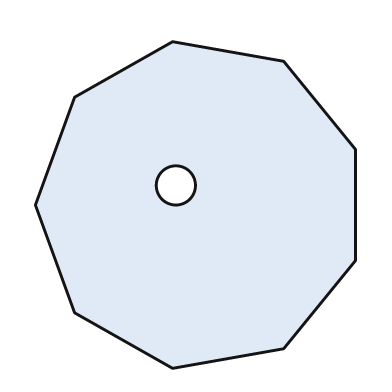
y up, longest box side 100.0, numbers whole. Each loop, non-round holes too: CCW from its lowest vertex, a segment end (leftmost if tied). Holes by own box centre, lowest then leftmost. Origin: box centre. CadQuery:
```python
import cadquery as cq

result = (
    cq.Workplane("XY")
    .moveTo(-7.0, -50.0)
    .lineTo(27.0, -44.0)
    .lineTo(49.0, -17.0)
    .lineTo(49.0, 17.0)
    .lineTo(27.0, 44.0)
    .lineTo(-7.0, 50.0)
    .lineTo(-37.0, 33.0)
    .lineTo(-49.0, 0.0)
    .lineTo(-37.0, -33.0)
    .close()
    .moveTo(-6.0, 6.0)
    .circle(6.0)
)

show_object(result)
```